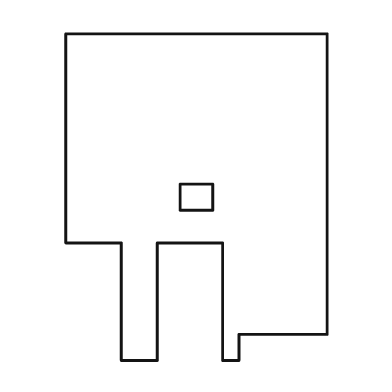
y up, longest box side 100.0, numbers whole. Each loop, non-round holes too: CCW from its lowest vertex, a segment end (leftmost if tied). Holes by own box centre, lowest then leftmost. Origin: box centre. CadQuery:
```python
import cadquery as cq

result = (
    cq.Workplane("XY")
    .moveTo(-23.0, -50.0)
    .lineTo(-12.0, -50.0)
    .lineTo(-12.0, -14.0)
    .lineTo(8.0, -14.0)
    .lineTo(8.0, -50.0)
    .lineTo(13.0, -50.0)
    .lineTo(13.0, -42.0)
    .lineTo(40.0, -42.0)
    .lineTo(40.0, 50.0)
    .lineTo(-40.0, 50.0)
    .lineTo(-40.0, -14.0)
    .lineTo(-23.0, -14.0)
    .close()
    .moveTo(-5.0, -4.0)
    .lineTo(5.0, -4.0)
    .lineTo(5.0, 4.0)
    .lineTo(-5.0, 4.0)
    .close()
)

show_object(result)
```